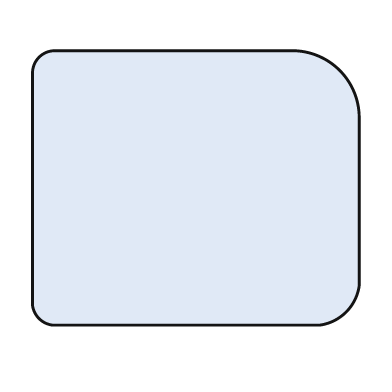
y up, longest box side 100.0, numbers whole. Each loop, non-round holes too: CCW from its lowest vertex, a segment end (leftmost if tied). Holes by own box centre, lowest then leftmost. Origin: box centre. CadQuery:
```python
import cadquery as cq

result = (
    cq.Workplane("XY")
    .moveTo(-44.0, -42.0)
    .lineTo(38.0, -42.0)
    .threePointArc((46.0, -38.0), (50.0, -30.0))
    .lineTo(50.0, 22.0)
    .threePointArc((44.0, 36.0), (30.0, 42.0))
    .lineTo(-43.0, 42.0)
    .threePointArc((-48.0, 40.0), (-50.0, 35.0))
    .lineTo(-50.0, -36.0)
    .threePointArc((-48.0, -40.0), (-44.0, -42.0))
    .close()
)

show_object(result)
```